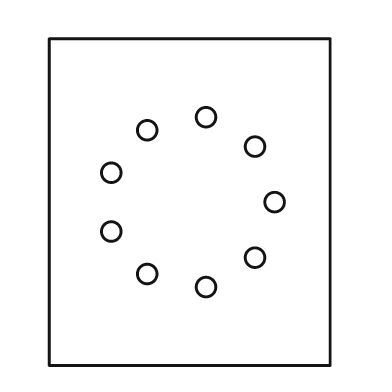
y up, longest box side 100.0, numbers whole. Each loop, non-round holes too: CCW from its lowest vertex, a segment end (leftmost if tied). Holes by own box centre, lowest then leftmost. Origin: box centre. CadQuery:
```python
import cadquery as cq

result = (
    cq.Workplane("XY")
    .moveTo(-43.0, -50.0)
    .lineTo(43.0, -50.0)
    .lineTo(43.0, 50.0)
    .lineTo(-43.0, 50.0)
    .close()
    .moveTo(5.0, -26.0)
    .circle(3.0)
    .moveTo(-13.0, -22.0)
    .circle(3.0)
    .moveTo(20.0, -17.0)
    .circle(3.0)
    .moveTo(-24.0, -9.0)
    .circle(3.0)
    .moveTo(26.0, 0.0)
    .circle(3.0)
    .moveTo(-24.0, 9.0)
    .circle(3.0)
    .moveTo(20.0, 17.0)
    .circle(3.0)
    .moveTo(-13.0, 22.0)
    .circle(3.0)
    .moveTo(5.0, 26.0)
    .circle(3.0)
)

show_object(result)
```